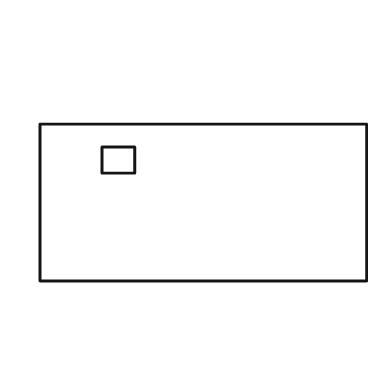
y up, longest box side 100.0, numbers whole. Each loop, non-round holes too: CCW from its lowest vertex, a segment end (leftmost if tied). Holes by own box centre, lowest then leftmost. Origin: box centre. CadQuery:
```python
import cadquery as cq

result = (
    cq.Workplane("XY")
    .moveTo(-50.0, -24.0)
    .lineTo(50.0, -24.0)
    .lineTo(50.0, 24.0)
    .lineTo(-50.0, 24.0)
    .close()
    .moveTo(-31.0, 9.0)
    .lineTo(-21.0, 9.0)
    .lineTo(-21.0, 17.0)
    .lineTo(-31.0, 17.0)
    .close()
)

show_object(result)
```